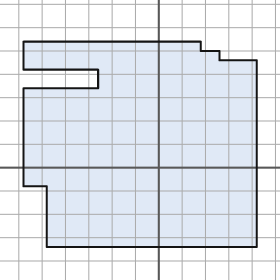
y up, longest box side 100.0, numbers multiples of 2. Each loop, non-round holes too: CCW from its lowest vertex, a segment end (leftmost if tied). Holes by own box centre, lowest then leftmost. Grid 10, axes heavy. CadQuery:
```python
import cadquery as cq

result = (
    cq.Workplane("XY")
    .moveTo(-48.0, -34.0)
    .lineTo(42.0, -34.0)
    .lineTo(42.0, 46.0)
    .lineTo(26.0, 46.0)
    .lineTo(26.0, 50.0)
    .lineTo(18.0, 50.0)
    .lineTo(18.0, 54.0)
    .lineTo(-58.0, 54.0)
    .lineTo(-58.0, 42.0)
    .lineTo(-26.0, 42.0)
    .lineTo(-26.0, 34.0)
    .lineTo(-58.0, 34.0)
    .lineTo(-58.0, -8.0)
    .lineTo(-48.0, -8.0)
    .close()
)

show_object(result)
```